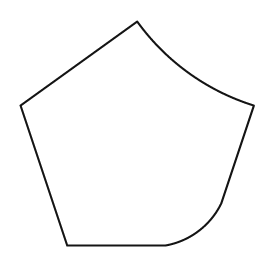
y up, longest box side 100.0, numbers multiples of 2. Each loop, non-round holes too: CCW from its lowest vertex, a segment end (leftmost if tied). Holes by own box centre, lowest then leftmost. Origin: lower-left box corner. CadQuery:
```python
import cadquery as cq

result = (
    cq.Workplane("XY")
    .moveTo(20.0, 0.0)
    .lineTo(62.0, 0.0)
    .threePointArc((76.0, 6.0), (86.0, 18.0))
    .lineTo(100.0, 60.0)
    .threePointArc((72.0, 74.0), (50.0, 96.0))
    .lineTo(0.0, 60.0)
    .close()
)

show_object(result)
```